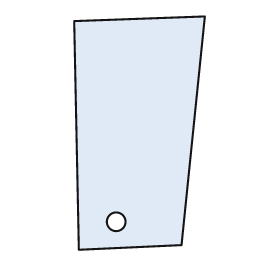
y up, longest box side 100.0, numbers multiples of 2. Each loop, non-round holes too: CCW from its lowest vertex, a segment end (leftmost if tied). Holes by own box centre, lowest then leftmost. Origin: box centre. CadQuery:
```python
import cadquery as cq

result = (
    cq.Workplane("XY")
    .moveTo(-26.0, -50.0)
    .lineTo(18.0, -48.0)
    .lineTo(28.0, 50.0)
    .lineTo(-28.0, 48.0)
    .close()
    .moveTo(-10.0, -38.0)
    .circle(4.0)
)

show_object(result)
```